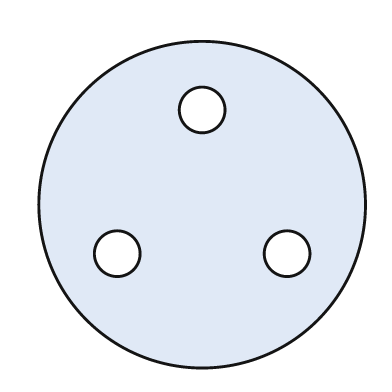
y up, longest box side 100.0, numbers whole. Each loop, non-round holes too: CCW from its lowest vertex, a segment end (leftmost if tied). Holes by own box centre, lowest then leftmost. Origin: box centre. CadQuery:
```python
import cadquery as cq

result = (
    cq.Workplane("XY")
    .moveTo(0.0, 0.0)
    .circle(50.0)
    .moveTo(-26.0, -15.0)
    .circle(7.0)
    .moveTo(26.0, -15.0)
    .circle(7.0)
    .moveTo(0.0, 29.0)
    .circle(7.0)
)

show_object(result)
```